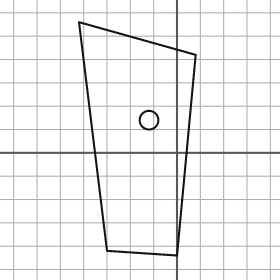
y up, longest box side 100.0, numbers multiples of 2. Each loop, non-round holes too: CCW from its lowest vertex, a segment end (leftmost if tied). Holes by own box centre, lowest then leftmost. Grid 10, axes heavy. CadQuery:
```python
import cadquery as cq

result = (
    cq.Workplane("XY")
    .moveTo(0.0, -44.0)
    .lineTo(8.0, 42.0)
    .lineTo(-42.0, 56.0)
    .lineTo(-30.0, -42.0)
    .close()
    .moveTo(-12.0, 14.0)
    .circle(4.0)
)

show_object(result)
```